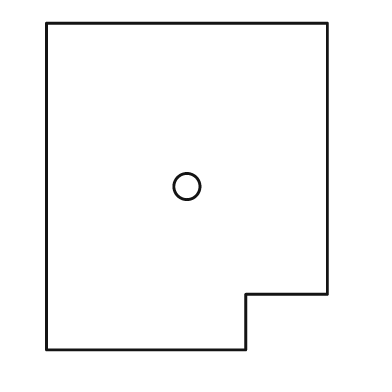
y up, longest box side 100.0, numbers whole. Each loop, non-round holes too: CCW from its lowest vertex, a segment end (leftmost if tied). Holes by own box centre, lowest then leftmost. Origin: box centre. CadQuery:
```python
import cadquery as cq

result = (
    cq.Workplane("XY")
    .moveTo(-43.0, -50.0)
    .lineTo(18.0, -50.0)
    .lineTo(18.0, -33.0)
    .lineTo(43.0, -33.0)
    .lineTo(43.0, 50.0)
    .lineTo(-43.0, 50.0)
    .close()
    .moveTo(0.0, 0.0)
    .circle(4.0)
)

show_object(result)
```